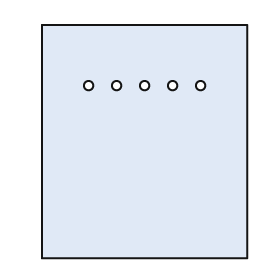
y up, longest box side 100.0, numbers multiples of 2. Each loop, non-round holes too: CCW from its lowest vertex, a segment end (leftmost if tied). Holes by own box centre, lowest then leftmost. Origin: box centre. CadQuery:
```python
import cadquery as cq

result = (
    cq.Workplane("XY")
    .moveTo(-44.0, -50.0)
    .lineTo(44.0, -50.0)
    .lineTo(44.0, 50.0)
    .lineTo(-44.0, 50.0)
    .close()
    .moveTo(-24.0, 24.0)
    .circle(2.0)
    .moveTo(-12.0, 24.0)
    .circle(2.0)
    .moveTo(0.0, 24.0)
    .circle(2.0)
    .moveTo(12.0, 24.0)
    .circle(2.0)
    .moveTo(24.0, 24.0)
    .circle(2.0)
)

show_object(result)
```